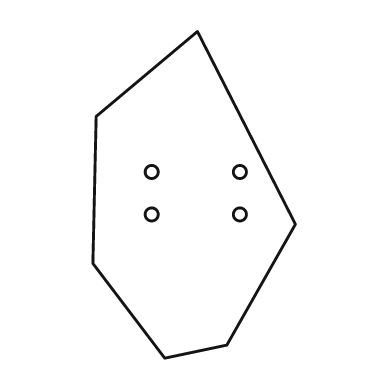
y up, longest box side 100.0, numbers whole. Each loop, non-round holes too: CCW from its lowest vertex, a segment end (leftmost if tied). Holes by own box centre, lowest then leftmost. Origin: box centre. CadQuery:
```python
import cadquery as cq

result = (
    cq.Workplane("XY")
    .moveTo(-9.0, -50.0)
    .lineTo(10.0, -46.0)
    .lineTo(31.0, -9.0)
    .lineTo(1.0, 50.0)
    .lineTo(-30.0, 24.0)
    .lineTo(-31.0, -21.0)
    .close()
    .moveTo(-13.0, -6.0)
    .circle(2.0)
    .moveTo(14.0, -6.0)
    .circle(2.0)
    .moveTo(-13.0, 7.0)
    .circle(2.0)
    .moveTo(14.0, 7.0)
    .circle(2.0)
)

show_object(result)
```